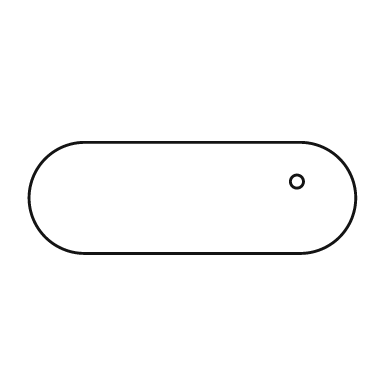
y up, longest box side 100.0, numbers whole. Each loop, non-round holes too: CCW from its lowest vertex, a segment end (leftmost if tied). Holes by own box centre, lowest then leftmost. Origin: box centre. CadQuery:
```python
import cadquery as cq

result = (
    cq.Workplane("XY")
    .moveTo(-33.0, -17.0)
    .lineTo(33.0, -17.0)
    .threePointArc((50.0, 0.0), (33.0, 17.0))
    .lineTo(-33.0, 17.0)
    .threePointArc((-50.0, 0.0), (-33.0, -17.0))
    .close()
    .moveTo(32.0, 5.0)
    .circle(2.0)
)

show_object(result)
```